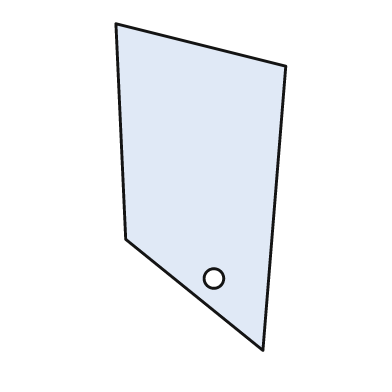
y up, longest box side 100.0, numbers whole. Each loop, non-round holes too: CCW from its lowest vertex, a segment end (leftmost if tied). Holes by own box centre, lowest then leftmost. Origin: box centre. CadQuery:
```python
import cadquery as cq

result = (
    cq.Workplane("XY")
    .moveTo(19.0, -50.0)
    .lineTo(26.0, 37.0)
    .lineTo(-26.0, 50.0)
    .lineTo(-23.0, -16.0)
    .close()
    .moveTo(4.0, -28.0)
    .circle(3.0)
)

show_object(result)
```